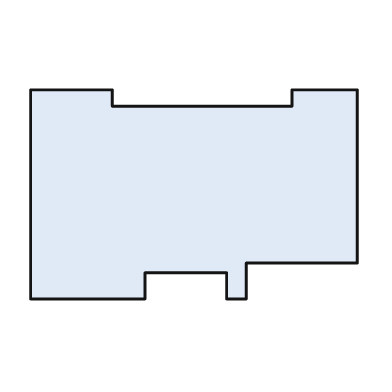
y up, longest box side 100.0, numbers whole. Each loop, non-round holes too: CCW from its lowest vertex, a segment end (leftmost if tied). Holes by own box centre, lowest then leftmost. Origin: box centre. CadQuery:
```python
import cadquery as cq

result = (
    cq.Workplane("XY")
    .moveTo(-50.0, -32.0)
    .lineTo(-15.0, -32.0)
    .lineTo(-15.0, -24.0)
    .lineTo(10.0, -24.0)
    .lineTo(10.0, -32.0)
    .lineTo(16.0, -32.0)
    .lineTo(16.0, -21.0)
    .lineTo(50.0, -21.0)
    .lineTo(50.0, 32.0)
    .lineTo(30.0, 32.0)
    .lineTo(30.0, 27.0)
    .lineTo(-25.0, 27.0)
    .lineTo(-25.0, 32.0)
    .lineTo(-50.0, 32.0)
    .close()
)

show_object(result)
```